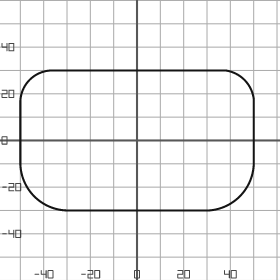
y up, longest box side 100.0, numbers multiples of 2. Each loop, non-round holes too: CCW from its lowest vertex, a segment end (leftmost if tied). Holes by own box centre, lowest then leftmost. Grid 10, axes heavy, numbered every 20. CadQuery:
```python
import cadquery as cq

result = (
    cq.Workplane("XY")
    .moveTo(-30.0, -30.0)
    .lineTo(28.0, -30.0)
    .threePointArc((44.0, -24.0), (50.0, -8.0))
    .lineTo(50.0, 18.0)
    .threePointArc((46.0, 26.0), (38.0, 30.0))
    .lineTo(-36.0, 30.0)
    .threePointArc((-46.0, 26.0), (-50.0, 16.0))
    .lineTo(-50.0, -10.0)
    .threePointArc((-44.0, -24.0), (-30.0, -30.0))
    .close()
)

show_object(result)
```